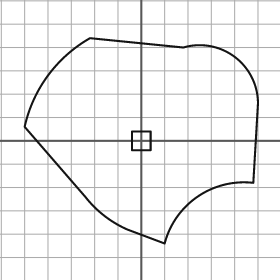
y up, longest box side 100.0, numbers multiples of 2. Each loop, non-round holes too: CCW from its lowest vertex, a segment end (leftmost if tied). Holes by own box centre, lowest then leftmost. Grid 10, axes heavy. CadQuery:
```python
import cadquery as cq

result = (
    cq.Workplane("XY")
    .moveTo(10.0, -44.0)
    .threePointArc((24.0, -24.0), (48.0, -18.0))
    .lineTo(50.0, 16.0)
    .threePointArc((40.0, 36.0), (18.0, 40.0))
    .lineTo(-22.0, 44.0)
    .threePointArc((-40.0, 28.0), (-50.0, 6.0))
    .lineTo(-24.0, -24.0)
    .threePointArc((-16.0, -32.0), (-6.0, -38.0))
    .close()
    .moveTo(-4.0, -4.0)
    .lineTo(4.0, -4.0)
    .lineTo(4.0, 4.0)
    .lineTo(-4.0, 4.0)
    .close()
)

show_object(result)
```